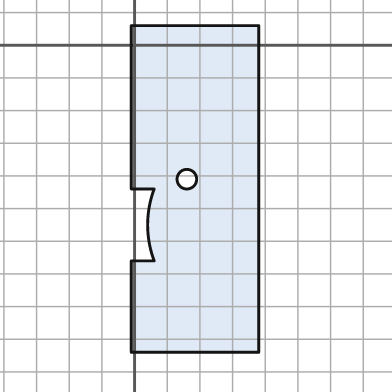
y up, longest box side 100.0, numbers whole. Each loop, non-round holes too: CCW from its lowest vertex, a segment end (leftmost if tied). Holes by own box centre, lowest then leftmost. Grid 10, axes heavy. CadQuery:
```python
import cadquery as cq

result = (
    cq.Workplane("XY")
    .moveTo(-1.0, -94.0)
    .lineTo(38.0, -94.0)
    .lineTo(38.0, 6.0)
    .lineTo(-1.0, 6.0)
    .lineTo(-1.0, -44.0)
    .lineTo(6.0, -44.0)
    .threePointArc((4.0, -55.0), (6.0, -66.0))
    .lineTo(-1.0, -66.0)
    .close()
    .moveTo(16.0, -41.0)
    .circle(3.0)
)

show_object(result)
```